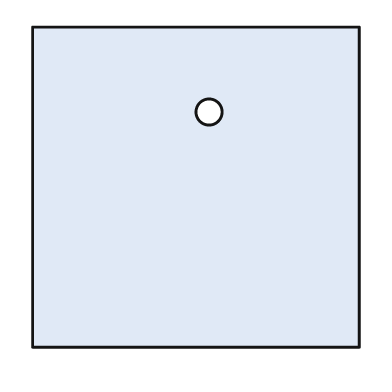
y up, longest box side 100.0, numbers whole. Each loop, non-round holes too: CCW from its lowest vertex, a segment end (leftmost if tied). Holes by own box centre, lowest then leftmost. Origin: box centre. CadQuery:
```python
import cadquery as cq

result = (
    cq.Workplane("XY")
    .moveTo(-50.0, -49.0)
    .lineTo(50.0, -49.0)
    .lineTo(50.0, 49.0)
    .lineTo(-50.0, 49.0)
    .close()
    .moveTo(4.0, 23.0)
    .circle(4.0)
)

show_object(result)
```